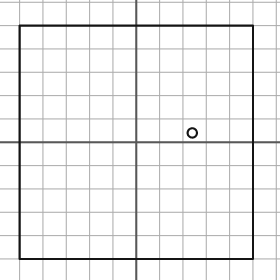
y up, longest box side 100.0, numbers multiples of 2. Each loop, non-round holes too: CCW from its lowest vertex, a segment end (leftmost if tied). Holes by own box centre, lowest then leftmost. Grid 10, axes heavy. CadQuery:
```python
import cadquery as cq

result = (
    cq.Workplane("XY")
    .moveTo(-50.0, -50.0)
    .lineTo(50.0, -50.0)
    .lineTo(50.0, 50.0)
    .lineTo(-50.0, 50.0)
    .close()
    .moveTo(24.0, 4.0)
    .circle(2.0)
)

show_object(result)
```